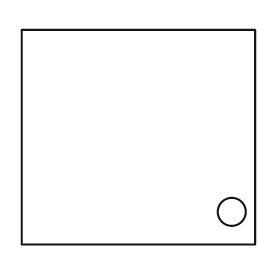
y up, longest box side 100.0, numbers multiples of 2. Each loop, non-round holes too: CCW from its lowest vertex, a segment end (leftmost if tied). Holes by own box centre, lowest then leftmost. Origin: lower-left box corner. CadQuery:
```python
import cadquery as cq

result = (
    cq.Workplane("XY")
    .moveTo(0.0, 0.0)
    .lineTo(100.0, 0.0)
    .lineTo(100.0, 92.0)
    .lineTo(0.0, 92.0)
    .close()
    .moveTo(90.0, 14.0)
    .circle(6.0)
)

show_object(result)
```